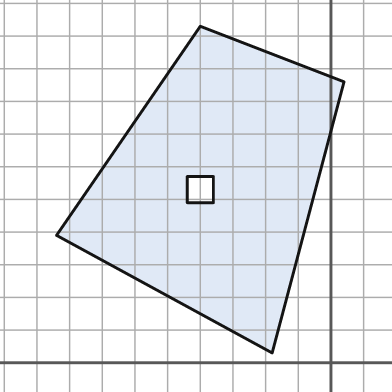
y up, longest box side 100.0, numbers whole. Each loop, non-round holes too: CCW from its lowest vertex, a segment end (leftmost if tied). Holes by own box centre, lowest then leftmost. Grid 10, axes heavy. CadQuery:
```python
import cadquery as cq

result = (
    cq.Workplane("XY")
    .moveTo(-18.0, 3.0)
    .lineTo(4.0, 86.0)
    .lineTo(-40.0, 103.0)
    .lineTo(-84.0, 39.0)
    .close()
    .moveTo(-44.0, 49.0)
    .lineTo(-36.0, 49.0)
    .lineTo(-36.0, 57.0)
    .lineTo(-44.0, 57.0)
    .close()
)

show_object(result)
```